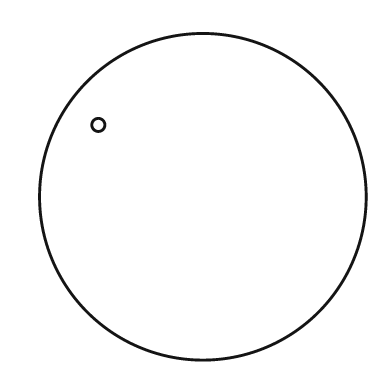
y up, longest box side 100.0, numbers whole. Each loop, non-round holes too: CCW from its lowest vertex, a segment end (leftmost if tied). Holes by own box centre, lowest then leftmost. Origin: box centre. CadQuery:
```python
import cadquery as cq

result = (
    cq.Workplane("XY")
    .moveTo(0.0, 0.0)
    .circle(50.0)
    .moveTo(-32.0, 22.0)
    .circle(2.0)
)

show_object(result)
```